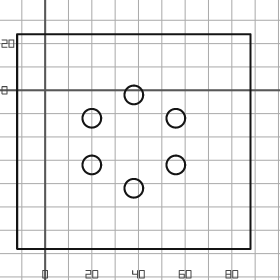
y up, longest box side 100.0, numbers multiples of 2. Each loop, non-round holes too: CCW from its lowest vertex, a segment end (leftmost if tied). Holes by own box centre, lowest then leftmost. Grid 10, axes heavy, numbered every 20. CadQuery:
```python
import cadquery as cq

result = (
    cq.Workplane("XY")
    .moveTo(-12.0, -68.0)
    .lineTo(88.0, -68.0)
    .lineTo(88.0, 24.0)
    .lineTo(-12.0, 24.0)
    .close()
    .moveTo(38.0, -42.0)
    .circle(4.0)
    .moveTo(20.0, -32.0)
    .circle(4.0)
    .moveTo(56.0, -32.0)
    .circle(4.0)
    .moveTo(20.0, -12.0)
    .circle(4.0)
    .moveTo(56.0, -12.0)
    .circle(4.0)
    .moveTo(38.0, -2.0)
    .circle(4.0)
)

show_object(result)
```